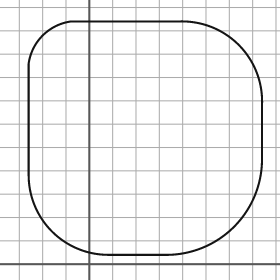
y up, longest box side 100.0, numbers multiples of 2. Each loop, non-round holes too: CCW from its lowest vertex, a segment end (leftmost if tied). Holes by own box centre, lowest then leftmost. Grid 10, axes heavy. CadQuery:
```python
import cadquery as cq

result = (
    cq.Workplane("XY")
    .moveTo(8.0, 4.0)
    .lineTo(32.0, 4.0)
    .threePointArc((62.0, 16.0), (74.0, 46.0))
    .lineTo(74.0, 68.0)
    .threePointArc((64.0, 94.0), (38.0, 104.0))
    .lineTo(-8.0, 104.0)
    .threePointArc((-20.0, 98.0), (-26.0, 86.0))
    .lineTo(-26.0, 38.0)
    .threePointArc((-16.0, 14.0), (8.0, 4.0))
    .close()
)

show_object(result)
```